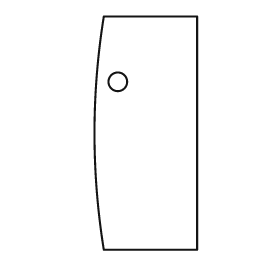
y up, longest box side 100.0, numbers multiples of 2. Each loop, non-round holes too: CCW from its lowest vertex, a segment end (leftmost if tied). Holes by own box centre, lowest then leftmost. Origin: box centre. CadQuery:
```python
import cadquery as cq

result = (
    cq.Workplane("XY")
    .moveTo(-18.0, -50.0)
    .lineTo(22.0, -50.0)
    .lineTo(22.0, 50.0)
    .lineTo(-18.0, 50.0)
    .threePointArc((-22.0, 0.0), (-18.0, -50.0))
    .close()
    .moveTo(-12.0, 22.0)
    .circle(4.0)
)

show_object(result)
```